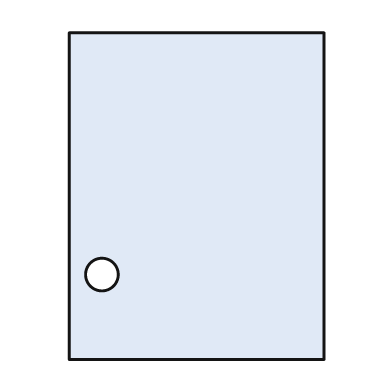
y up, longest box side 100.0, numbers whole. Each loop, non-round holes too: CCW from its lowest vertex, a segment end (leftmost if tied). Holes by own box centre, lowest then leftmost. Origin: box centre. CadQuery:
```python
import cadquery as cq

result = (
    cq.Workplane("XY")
    .moveTo(-39.0, -50.0)
    .lineTo(39.0, -50.0)
    .lineTo(39.0, 50.0)
    .lineTo(-39.0, 50.0)
    .close()
    .moveTo(-29.0, -24.0)
    .circle(5.0)
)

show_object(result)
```